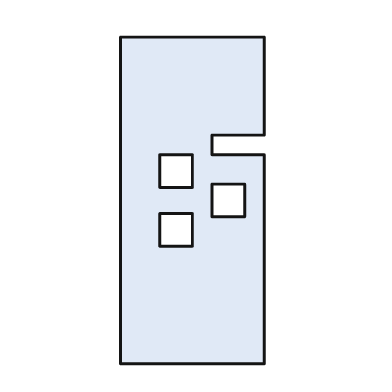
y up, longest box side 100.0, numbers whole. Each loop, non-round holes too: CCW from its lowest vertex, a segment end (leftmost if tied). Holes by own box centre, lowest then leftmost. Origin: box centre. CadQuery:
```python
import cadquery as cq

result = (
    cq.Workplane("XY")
    .moveTo(-22.0, -50.0)
    .lineTo(22.0, -50.0)
    .lineTo(22.0, 14.0)
    .lineTo(6.0, 14.0)
    .lineTo(6.0, 20.0)
    .lineTo(22.0, 20.0)
    .lineTo(22.0, 50.0)
    .lineTo(-22.0, 50.0)
    .close()
    .moveTo(-10.0, -14.0)
    .lineTo(0.0, -14.0)
    .lineTo(0.0, -4.0)
    .lineTo(-10.0, -4.0)
    .close()
    .moveTo(6.0, -5.0)
    .lineTo(16.0, -5.0)
    .lineTo(16.0, 5.0)
    .lineTo(6.0, 5.0)
    .close()
    .moveTo(-10.0, 4.0)
    .lineTo(0.0, 4.0)
    .lineTo(0.0, 14.0)
    .lineTo(-10.0, 14.0)
    .close()
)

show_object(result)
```